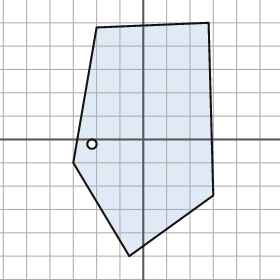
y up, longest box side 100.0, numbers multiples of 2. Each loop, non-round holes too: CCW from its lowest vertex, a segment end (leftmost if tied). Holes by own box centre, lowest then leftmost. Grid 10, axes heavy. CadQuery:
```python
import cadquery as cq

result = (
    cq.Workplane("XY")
    .moveTo(-6.0, -50.0)
    .lineTo(30.0, -24.0)
    .lineTo(28.0, 50.0)
    .lineTo(-20.0, 48.0)
    .lineTo(-30.0, -10.0)
    .close()
    .moveTo(-22.0, -2.0)
    .circle(2.0)
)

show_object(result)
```